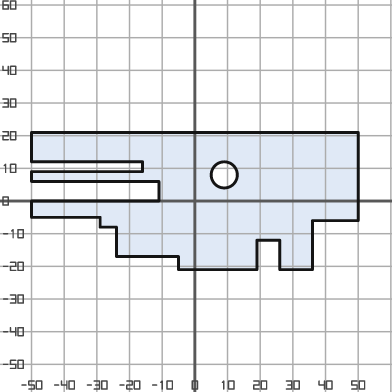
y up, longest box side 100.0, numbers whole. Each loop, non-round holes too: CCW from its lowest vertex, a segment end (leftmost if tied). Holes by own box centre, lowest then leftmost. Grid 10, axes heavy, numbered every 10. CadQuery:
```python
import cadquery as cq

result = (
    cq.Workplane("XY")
    .moveTo(-5.0, -21.0)
    .lineTo(19.0, -21.0)
    .lineTo(19.0, -12.0)
    .lineTo(26.0, -12.0)
    .lineTo(26.0, -21.0)
    .lineTo(36.0, -21.0)
    .lineTo(36.0, -6.0)
    .lineTo(50.0, -6.0)
    .lineTo(50.0, 21.0)
    .lineTo(-50.0, 21.0)
    .lineTo(-50.0, 12.0)
    .lineTo(-16.0, 12.0)
    .lineTo(-16.0, 9.0)
    .lineTo(-50.0, 9.0)
    .lineTo(-50.0, 6.0)
    .lineTo(-11.0, 6.0)
    .lineTo(-11.0, 0.0)
    .lineTo(-50.0, 0.0)
    .lineTo(-50.0, -5.0)
    .lineTo(-29.0, -5.0)
    .lineTo(-29.0, -8.0)
    .lineTo(-24.0, -8.0)
    .lineTo(-24.0, -17.0)
    .lineTo(-5.0, -17.0)
    .close()
    .moveTo(9.0, 8.0)
    .circle(4.0)
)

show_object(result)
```